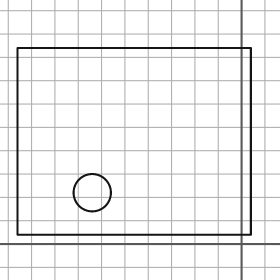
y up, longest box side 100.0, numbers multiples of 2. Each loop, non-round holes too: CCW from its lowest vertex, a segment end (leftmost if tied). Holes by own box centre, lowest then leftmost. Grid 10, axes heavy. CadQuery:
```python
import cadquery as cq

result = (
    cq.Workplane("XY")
    .moveTo(-96.0, 4.0)
    .lineTo(4.0, 4.0)
    .lineTo(4.0, 84.0)
    .lineTo(-96.0, 84.0)
    .close()
    .moveTo(-64.0, 22.0)
    .circle(8.0)
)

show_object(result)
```